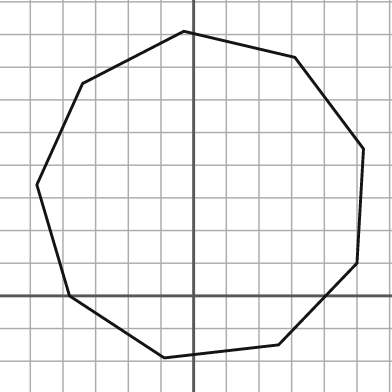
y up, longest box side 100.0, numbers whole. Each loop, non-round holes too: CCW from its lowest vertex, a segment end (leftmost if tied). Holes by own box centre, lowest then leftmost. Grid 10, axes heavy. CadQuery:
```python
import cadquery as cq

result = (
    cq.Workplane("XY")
    .moveTo(-9.0, -19.0)
    .lineTo(26.0, -15.0)
    .lineTo(50.0, 10.0)
    .lineTo(52.0, 45.0)
    .lineTo(31.0, 73.0)
    .lineTo(-3.0, 81.0)
    .lineTo(-34.0, 65.0)
    .lineTo(-48.0, 34.0)
    .lineTo(-38.0, 0.0)
    .close()
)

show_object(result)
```